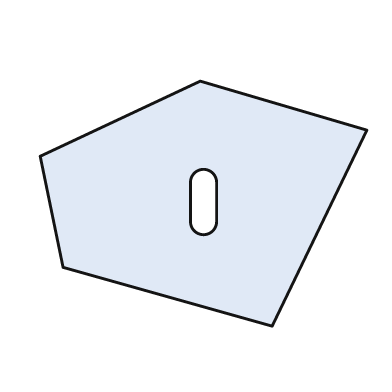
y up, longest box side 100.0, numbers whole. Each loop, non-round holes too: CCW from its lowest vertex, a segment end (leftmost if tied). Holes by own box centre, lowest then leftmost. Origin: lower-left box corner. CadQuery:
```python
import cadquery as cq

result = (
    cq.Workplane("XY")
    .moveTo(71.0, 0.0)
    .lineTo(100.0, 60.0)
    .lineTo(49.0, 75.0)
    .lineTo(0.0, 52.0)
    .lineTo(7.0, 18.0)
    .close()
    .moveTo(46.0, 32.0)
    .threePointArc((50.0, 28.0), (54.0, 32.0))
    .lineTo(54.0, 44.0)
    .threePointArc((50.0, 48.0), (46.0, 44.0))
    .close()
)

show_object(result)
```